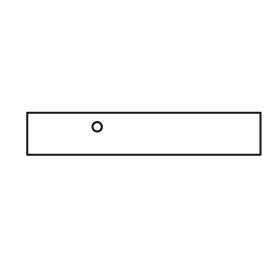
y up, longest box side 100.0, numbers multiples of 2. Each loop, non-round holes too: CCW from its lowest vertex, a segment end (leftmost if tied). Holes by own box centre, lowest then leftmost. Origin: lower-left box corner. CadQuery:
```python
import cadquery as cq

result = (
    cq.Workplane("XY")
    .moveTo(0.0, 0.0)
    .lineTo(100.0, 0.0)
    .lineTo(100.0, 18.0)
    .lineTo(0.0, 18.0)
    .close()
    .moveTo(30.0, 12.0)
    .circle(2.0)
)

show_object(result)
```